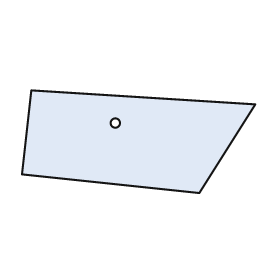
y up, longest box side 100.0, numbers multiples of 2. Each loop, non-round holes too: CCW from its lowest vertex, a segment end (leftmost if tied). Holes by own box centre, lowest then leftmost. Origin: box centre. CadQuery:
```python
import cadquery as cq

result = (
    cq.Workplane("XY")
    .moveTo(26.0, -22.0)
    .lineTo(50.0, 16.0)
    .lineTo(-46.0, 22.0)
    .lineTo(-50.0, -14.0)
    .close()
    .moveTo(-10.0, 8.0)
    .circle(2.0)
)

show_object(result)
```